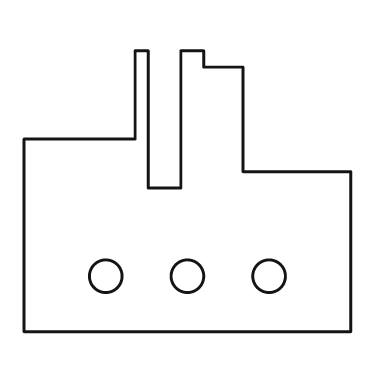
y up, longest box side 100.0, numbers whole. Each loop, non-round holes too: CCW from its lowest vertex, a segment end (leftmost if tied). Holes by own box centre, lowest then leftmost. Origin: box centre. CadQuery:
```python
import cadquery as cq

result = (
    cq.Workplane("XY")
    .moveTo(-50.0, -43.0)
    .lineTo(50.0, -43.0)
    .lineTo(50.0, 6.0)
    .lineTo(17.0, 6.0)
    .lineTo(17.0, 38.0)
    .lineTo(5.0, 38.0)
    .lineTo(5.0, 43.0)
    .lineTo(-2.0, 43.0)
    .lineTo(-2.0, 1.0)
    .lineTo(-12.0, 1.0)
    .lineTo(-12.0, 43.0)
    .lineTo(-16.0, 43.0)
    .lineTo(-16.0, 16.0)
    .lineTo(-50.0, 16.0)
    .close()
    .moveTo(-25.0, -26.0)
    .circle(5.0)
    .moveTo(0.0, -26.0)
    .circle(5.0)
    .moveTo(25.0, -26.0)
    .circle(5.0)
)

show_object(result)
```